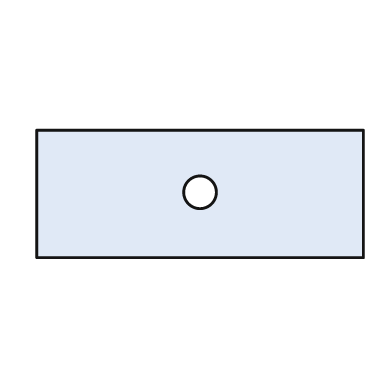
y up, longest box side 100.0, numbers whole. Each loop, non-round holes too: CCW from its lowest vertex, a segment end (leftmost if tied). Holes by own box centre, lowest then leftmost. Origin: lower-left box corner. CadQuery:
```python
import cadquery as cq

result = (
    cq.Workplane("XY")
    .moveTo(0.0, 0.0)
    .lineTo(100.0, 0.0)
    .lineTo(100.0, 39.0)
    .lineTo(0.0, 39.0)
    .close()
    .moveTo(50.0, 20.0)
    .circle(5.0)
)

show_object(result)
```